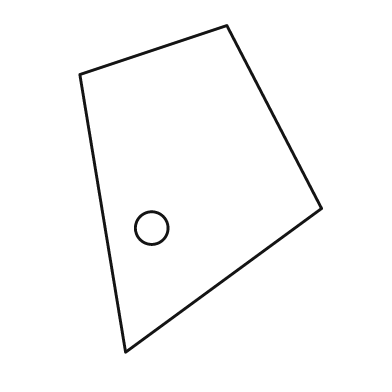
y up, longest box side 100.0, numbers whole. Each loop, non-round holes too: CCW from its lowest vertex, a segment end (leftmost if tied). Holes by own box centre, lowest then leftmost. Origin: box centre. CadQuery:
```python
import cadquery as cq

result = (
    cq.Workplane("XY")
    .moveTo(-23.0, -50.0)
    .lineTo(37.0, -6.0)
    .lineTo(8.0, 50.0)
    .lineTo(-37.0, 35.0)
    .close()
    .moveTo(-15.0, -12.0)
    .circle(5.0)
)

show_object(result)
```